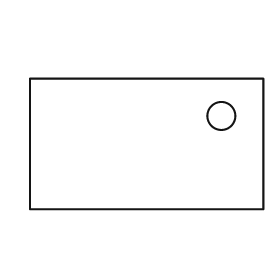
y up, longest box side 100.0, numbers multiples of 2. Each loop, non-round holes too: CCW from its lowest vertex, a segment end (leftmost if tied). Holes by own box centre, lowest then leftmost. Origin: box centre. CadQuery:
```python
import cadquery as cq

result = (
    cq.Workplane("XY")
    .moveTo(-50.0, -28.0)
    .lineTo(50.0, -28.0)
    .lineTo(50.0, 28.0)
    .lineTo(-50.0, 28.0)
    .close()
    .moveTo(32.0, 12.0)
    .circle(6.0)
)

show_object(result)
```